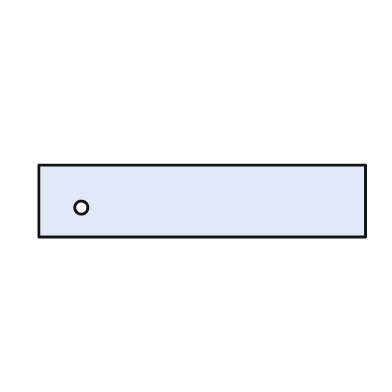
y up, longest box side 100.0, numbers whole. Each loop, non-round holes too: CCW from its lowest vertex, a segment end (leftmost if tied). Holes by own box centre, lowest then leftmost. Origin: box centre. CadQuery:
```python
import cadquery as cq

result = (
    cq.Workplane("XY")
    .moveTo(-50.0, -11.0)
    .lineTo(50.0, -11.0)
    .lineTo(50.0, 11.0)
    .lineTo(-50.0, 11.0)
    .close()
    .moveTo(-37.0, -2.0)
    .circle(2.0)
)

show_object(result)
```